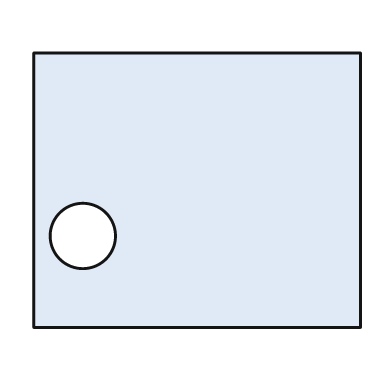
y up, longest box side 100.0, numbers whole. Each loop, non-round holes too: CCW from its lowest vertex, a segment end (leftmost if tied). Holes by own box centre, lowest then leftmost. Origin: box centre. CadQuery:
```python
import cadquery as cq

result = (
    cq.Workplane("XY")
    .moveTo(-50.0, -42.0)
    .lineTo(50.0, -42.0)
    .lineTo(50.0, 42.0)
    .lineTo(-50.0, 42.0)
    .close()
    .moveTo(-35.0, -14.0)
    .circle(10.0)
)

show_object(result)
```